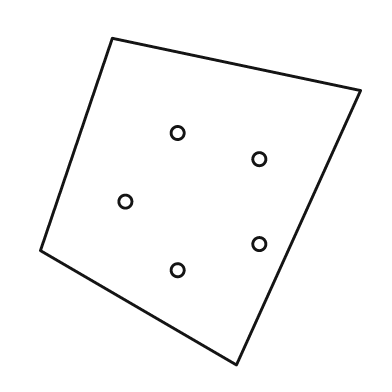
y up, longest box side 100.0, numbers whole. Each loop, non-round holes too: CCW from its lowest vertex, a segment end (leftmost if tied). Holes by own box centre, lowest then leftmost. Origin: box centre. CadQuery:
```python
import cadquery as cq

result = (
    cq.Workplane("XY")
    .moveTo(11.0, -50.0)
    .lineTo(49.0, 34.0)
    .lineTo(-27.0, 50.0)
    .lineTo(-49.0, -15.0)
    .close()
    .moveTo(-7.0, -21.0)
    .circle(2.0)
    .moveTo(18.0, -13.0)
    .circle(2.0)
    .moveTo(-23.0, 0.0)
    .circle(2.0)
    .moveTo(18.0, 13.0)
    .circle(2.0)
    .moveTo(-7.0, 21.0)
    .circle(2.0)
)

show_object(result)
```